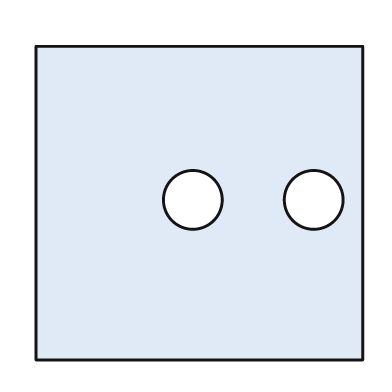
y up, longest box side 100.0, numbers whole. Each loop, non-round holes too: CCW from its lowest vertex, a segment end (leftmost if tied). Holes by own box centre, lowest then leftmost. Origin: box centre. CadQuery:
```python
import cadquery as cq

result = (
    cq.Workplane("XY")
    .moveTo(-50.0, -48.0)
    .lineTo(50.0, -48.0)
    .lineTo(50.0, 48.0)
    .lineTo(-50.0, 48.0)
    .close()
    .moveTo(-2.0, 1.0)
    .circle(9.0)
    .moveTo(35.0, 1.0)
    .circle(9.0)
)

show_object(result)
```